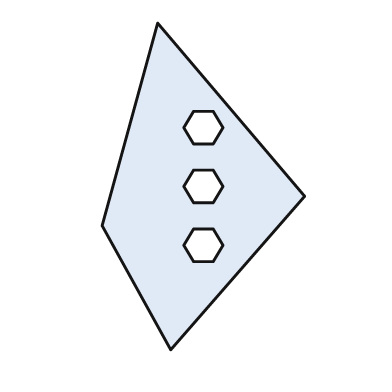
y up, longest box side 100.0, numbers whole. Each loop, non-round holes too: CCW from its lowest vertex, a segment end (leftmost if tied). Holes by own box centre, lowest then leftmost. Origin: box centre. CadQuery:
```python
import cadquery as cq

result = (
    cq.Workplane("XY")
    .moveTo(-10.0, -50.0)
    .lineTo(31.0, -3.0)
    .lineTo(-14.0, 50.0)
    .lineTo(-31.0, -12.0)
    .close()
    .moveTo(-3.0, -23.0)
    .lineTo(3.0, -23.0)
    .lineTo(6.0, -18.0)
    .lineTo(3.0, -13.0)
    .lineTo(-3.0, -13.0)
    .lineTo(-6.0, -18.0)
    .close()
    .moveTo(-3.0, -5.0)
    .lineTo(3.0, -5.0)
    .lineTo(6.0, 0.0)
    .lineTo(3.0, 5.0)
    .lineTo(-3.0, 5.0)
    .lineTo(-6.0, 0.0)
    .close()
    .moveTo(-3.0, 13.0)
    .lineTo(3.0, 13.0)
    .lineTo(6.0, 18.0)
    .lineTo(3.0, 23.0)
    .lineTo(-3.0, 23.0)
    .lineTo(-6.0, 18.0)
    .close()
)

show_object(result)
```